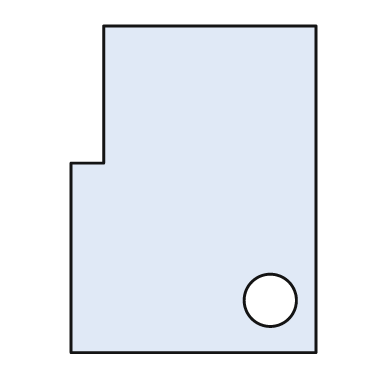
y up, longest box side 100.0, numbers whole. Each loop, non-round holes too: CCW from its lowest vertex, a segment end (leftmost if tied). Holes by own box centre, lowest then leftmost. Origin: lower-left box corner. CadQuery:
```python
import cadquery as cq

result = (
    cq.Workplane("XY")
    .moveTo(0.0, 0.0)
    .lineTo(75.0, 0.0)
    .lineTo(75.0, 100.0)
    .lineTo(10.0, 100.0)
    .lineTo(10.0, 58.0)
    .lineTo(0.0, 58.0)
    .close()
    .moveTo(61.0, 16.0)
    .circle(8.0)
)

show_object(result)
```